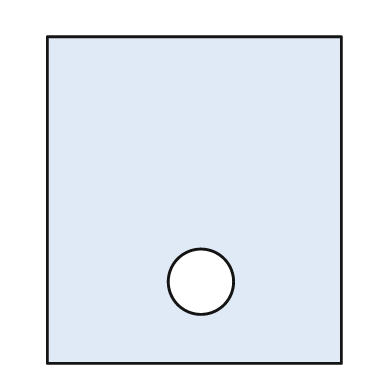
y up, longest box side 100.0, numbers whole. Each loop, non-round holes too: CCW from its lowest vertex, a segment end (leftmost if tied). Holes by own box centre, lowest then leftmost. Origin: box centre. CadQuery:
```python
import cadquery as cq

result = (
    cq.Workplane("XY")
    .moveTo(-45.0, -50.0)
    .lineTo(45.0, -50.0)
    .lineTo(45.0, 50.0)
    .lineTo(-45.0, 50.0)
    .close()
    .moveTo(2.0, -25.0)
    .circle(10.0)
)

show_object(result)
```